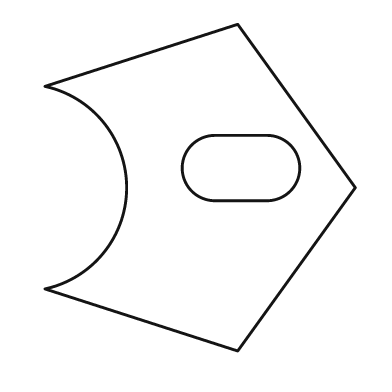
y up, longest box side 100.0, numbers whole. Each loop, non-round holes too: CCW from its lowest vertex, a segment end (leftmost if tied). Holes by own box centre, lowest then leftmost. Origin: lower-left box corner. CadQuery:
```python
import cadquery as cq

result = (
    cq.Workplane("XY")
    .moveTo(59.0, 0.0)
    .lineTo(95.0, 50.0)
    .lineTo(59.0, 100.0)
    .lineTo(0.0, 81.0)
    .threePointArc((25.0, 50.0), (0.0, 19.0))
    .close()
    .moveTo(52.0, 46.0)
    .lineTo(68.0, 46.0)
    .threePointArc((78.0, 56.0), (68.0, 66.0))
    .lineTo(52.0, 66.0)
    .threePointArc((42.0, 56.0), (52.0, 46.0))
    .close()
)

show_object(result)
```